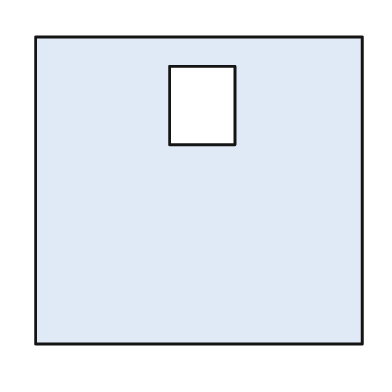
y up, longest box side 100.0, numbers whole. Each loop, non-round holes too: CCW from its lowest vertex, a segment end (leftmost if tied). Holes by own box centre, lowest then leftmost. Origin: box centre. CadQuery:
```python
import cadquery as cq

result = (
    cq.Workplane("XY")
    .moveTo(-50.0, -47.0)
    .lineTo(50.0, -47.0)
    .lineTo(50.0, 47.0)
    .lineTo(-50.0, 47.0)
    .close()
    .moveTo(-9.0, 14.0)
    .lineTo(11.0, 14.0)
    .lineTo(11.0, 38.0)
    .lineTo(-9.0, 38.0)
    .close()
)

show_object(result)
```